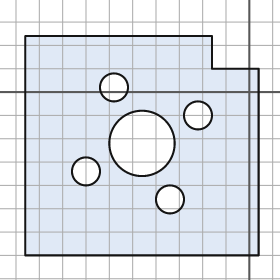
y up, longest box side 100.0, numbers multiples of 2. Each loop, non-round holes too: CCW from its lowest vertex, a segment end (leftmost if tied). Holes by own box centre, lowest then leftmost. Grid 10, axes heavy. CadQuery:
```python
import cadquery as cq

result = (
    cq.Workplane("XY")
    .moveTo(-96.0, -70.0)
    .lineTo(4.0, -70.0)
    .lineTo(4.0, 10.0)
    .lineTo(-16.0, 10.0)
    .lineTo(-16.0, 24.0)
    .lineTo(-96.0, 24.0)
    .close()
    .moveTo(-34.0, -46.0)
    .circle(6.0)
    .moveTo(-70.0, -34.0)
    .circle(6.0)
    .moveTo(-46.0, -22.0)
    .circle(14.0)
    .moveTo(-22.0, -10.0)
    .circle(6.0)
    .moveTo(-58.0, 2.0)
    .circle(6.0)
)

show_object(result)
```